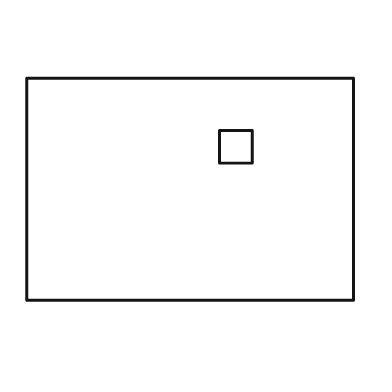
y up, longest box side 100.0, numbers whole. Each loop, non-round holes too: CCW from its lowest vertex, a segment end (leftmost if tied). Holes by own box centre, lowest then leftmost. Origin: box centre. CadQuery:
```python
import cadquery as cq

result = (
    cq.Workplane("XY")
    .moveTo(-50.0, -34.0)
    .lineTo(50.0, -34.0)
    .lineTo(50.0, 34.0)
    .lineTo(-50.0, 34.0)
    .close()
    .moveTo(9.0, 8.0)
    .lineTo(19.0, 8.0)
    .lineTo(19.0, 18.0)
    .lineTo(9.0, 18.0)
    .close()
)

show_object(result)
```